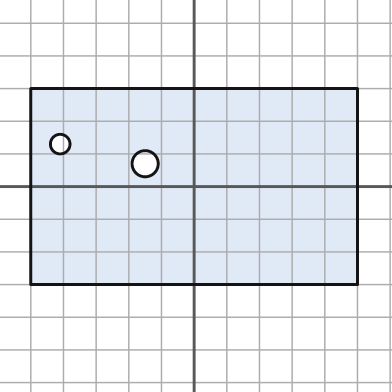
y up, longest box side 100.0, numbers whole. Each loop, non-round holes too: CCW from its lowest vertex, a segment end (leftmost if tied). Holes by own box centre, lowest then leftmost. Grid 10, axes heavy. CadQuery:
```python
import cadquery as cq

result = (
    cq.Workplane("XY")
    .moveTo(-50.0, -30.0)
    .lineTo(50.0, -30.0)
    .lineTo(50.0, 30.0)
    .lineTo(-50.0, 30.0)
    .close()
    .moveTo(-15.0, 7.0)
    .circle(4.0)
    .moveTo(-41.0, 13.0)
    .circle(3.0)
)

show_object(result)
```